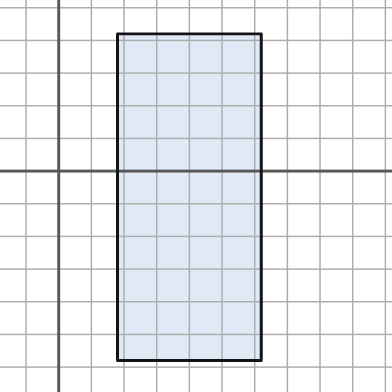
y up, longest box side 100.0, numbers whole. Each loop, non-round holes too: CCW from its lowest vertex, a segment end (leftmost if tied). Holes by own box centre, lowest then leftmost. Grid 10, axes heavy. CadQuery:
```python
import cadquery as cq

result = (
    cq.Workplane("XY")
    .moveTo(18.0, -58.0)
    .lineTo(62.0, -58.0)
    .lineTo(62.0, 42.0)
    .lineTo(18.0, 42.0)
    .close()
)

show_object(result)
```